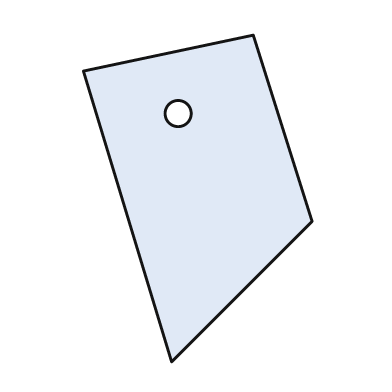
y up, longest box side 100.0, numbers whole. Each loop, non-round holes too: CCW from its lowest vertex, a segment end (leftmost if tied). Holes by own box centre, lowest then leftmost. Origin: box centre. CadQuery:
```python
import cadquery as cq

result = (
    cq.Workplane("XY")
    .moveTo(-8.0, -50.0)
    .lineTo(35.0, -7.0)
    .lineTo(17.0, 50.0)
    .lineTo(-35.0, 39.0)
    .close()
    .moveTo(-6.0, 26.0)
    .circle(4.0)
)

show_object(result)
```